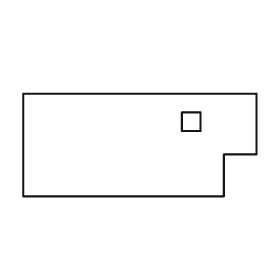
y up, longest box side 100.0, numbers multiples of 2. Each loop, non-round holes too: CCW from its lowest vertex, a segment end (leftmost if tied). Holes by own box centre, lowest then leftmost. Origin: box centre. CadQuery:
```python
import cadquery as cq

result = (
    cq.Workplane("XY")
    .moveTo(-50.0, -22.0)
    .lineTo(36.0, -22.0)
    .lineTo(36.0, -4.0)
    .lineTo(50.0, -4.0)
    .lineTo(50.0, 22.0)
    .lineTo(-50.0, 22.0)
    .close()
    .moveTo(18.0, 6.0)
    .lineTo(26.0, 6.0)
    .lineTo(26.0, 14.0)
    .lineTo(18.0, 14.0)
    .close()
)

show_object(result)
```